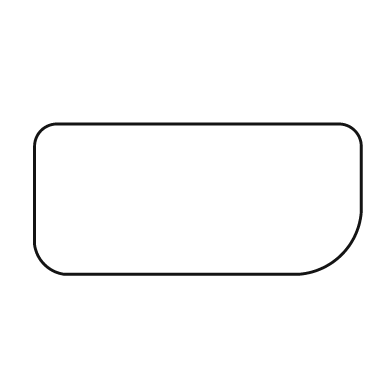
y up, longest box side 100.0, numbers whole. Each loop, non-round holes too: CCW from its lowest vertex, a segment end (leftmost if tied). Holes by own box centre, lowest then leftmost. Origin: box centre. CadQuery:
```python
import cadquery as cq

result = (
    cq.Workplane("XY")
    .moveTo(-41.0, -23.0)
    .lineTo(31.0, -23.0)
    .threePointArc((44.0, -17.0), (50.0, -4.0))
    .lineTo(50.0, 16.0)
    .threePointArc((48.0, 21.0), (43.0, 23.0))
    .lineTo(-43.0, 23.0)
    .threePointArc((-48.0, 21.0), (-50.0, 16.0))
    .lineTo(-50.0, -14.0)
    .threePointArc((-47.0, -20.0), (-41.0, -23.0))
    .close()
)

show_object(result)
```